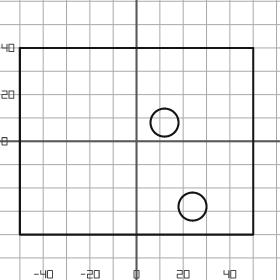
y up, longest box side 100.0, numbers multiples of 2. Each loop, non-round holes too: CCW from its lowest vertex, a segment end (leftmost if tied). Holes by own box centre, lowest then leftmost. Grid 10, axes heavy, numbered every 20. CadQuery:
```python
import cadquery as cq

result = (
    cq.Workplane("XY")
    .moveTo(-50.0, -40.0)
    .lineTo(50.0, -40.0)
    .lineTo(50.0, 40.0)
    .lineTo(-50.0, 40.0)
    .close()
    .moveTo(24.0, -28.0)
    .circle(6.0)
    .moveTo(12.0, 8.0)
    .circle(6.0)
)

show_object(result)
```